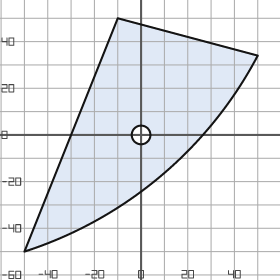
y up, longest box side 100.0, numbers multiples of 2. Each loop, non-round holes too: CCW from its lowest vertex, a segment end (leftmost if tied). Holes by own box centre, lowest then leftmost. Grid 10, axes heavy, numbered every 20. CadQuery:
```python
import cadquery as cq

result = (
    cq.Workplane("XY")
    .moveTo(-50.0, -50.0)
    .threePointArc((8.0, -18.0), (50.0, 34.0))
    .lineTo(-10.0, 50.0)
    .close()
    .moveTo(0.0, 0.0)
    .circle(4.0)
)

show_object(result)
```